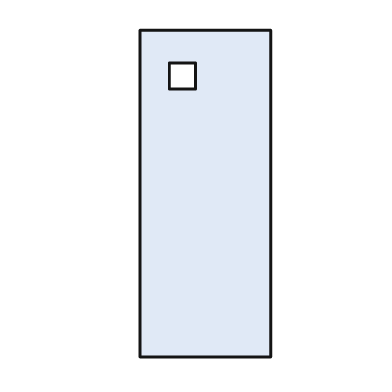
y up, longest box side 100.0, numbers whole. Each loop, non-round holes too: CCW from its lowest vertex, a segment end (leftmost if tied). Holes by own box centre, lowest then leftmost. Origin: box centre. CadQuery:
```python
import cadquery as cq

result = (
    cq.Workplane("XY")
    .moveTo(-20.0, -50.0)
    .lineTo(20.0, -50.0)
    .lineTo(20.0, 50.0)
    .lineTo(-20.0, 50.0)
    .close()
    .moveTo(-11.0, 32.0)
    .lineTo(-3.0, 32.0)
    .lineTo(-3.0, 40.0)
    .lineTo(-11.0, 40.0)
    .close()
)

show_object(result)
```